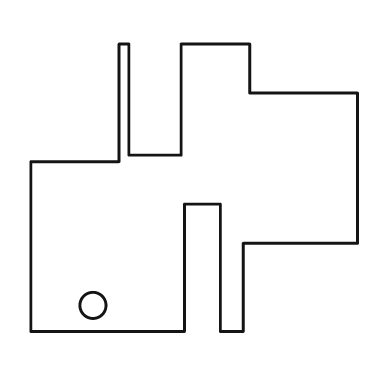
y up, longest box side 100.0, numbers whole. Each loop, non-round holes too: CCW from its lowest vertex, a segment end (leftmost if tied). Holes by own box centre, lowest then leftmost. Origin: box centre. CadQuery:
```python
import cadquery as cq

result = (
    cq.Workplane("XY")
    .moveTo(-50.0, -44.0)
    .lineTo(-3.0, -44.0)
    .lineTo(-3.0, -5.0)
    .lineTo(8.0, -5.0)
    .lineTo(8.0, -44.0)
    .lineTo(15.0, -44.0)
    .lineTo(15.0, -17.0)
    .lineTo(50.0, -17.0)
    .lineTo(50.0, 29.0)
    .lineTo(17.0, 29.0)
    .lineTo(17.0, 44.0)
    .lineTo(-4.0, 44.0)
    .lineTo(-4.0, 10.0)
    .lineTo(-20.0, 10.0)
    .lineTo(-20.0, 44.0)
    .lineTo(-23.0, 44.0)
    .lineTo(-23.0, 8.0)
    .lineTo(-50.0, 8.0)
    .close()
    .moveTo(-31.0, -36.0)
    .circle(4.0)
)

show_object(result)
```